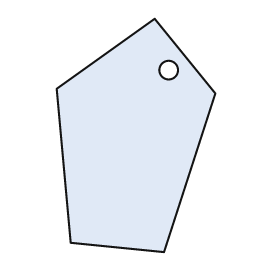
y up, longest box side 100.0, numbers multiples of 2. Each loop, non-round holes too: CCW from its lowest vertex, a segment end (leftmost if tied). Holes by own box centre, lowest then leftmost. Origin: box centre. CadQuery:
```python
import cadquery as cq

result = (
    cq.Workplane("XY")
    .moveTo(12.0, -50.0)
    .lineTo(34.0, 18.0)
    .lineTo(8.0, 50.0)
    .lineTo(-34.0, 20.0)
    .lineTo(-28.0, -46.0)
    .close()
    .moveTo(14.0, 28.0)
    .circle(4.0)
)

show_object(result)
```